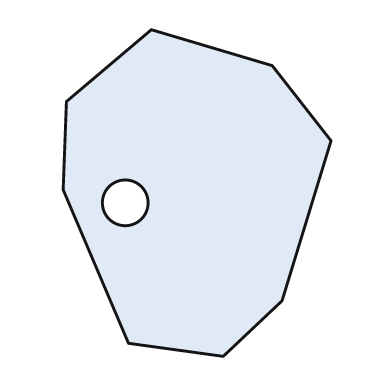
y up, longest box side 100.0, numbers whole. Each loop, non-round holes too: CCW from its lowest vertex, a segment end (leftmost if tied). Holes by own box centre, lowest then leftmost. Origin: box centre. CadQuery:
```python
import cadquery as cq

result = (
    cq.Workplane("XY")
    .moveTo(8.0, -50.0)
    .lineTo(26.0, -33.0)
    .lineTo(41.0, 16.0)
    .lineTo(23.0, 39.0)
    .lineTo(-14.0, 50.0)
    .lineTo(-40.0, 28.0)
    .lineTo(-41.0, 1.0)
    .lineTo(-21.0, -46.0)
    .close()
    .moveTo(-22.0, -3.0)
    .circle(7.0)
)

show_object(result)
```